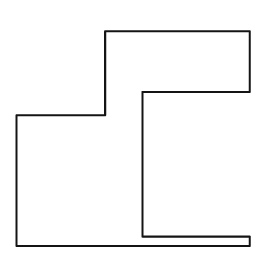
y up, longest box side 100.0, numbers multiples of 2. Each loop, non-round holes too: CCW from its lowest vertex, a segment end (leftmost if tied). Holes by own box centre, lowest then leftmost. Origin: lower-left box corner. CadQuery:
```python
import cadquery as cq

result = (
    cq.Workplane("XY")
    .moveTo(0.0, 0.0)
    .lineTo(100.0, 0.0)
    .lineTo(100.0, 4.0)
    .lineTo(54.0, 4.0)
    .lineTo(54.0, 66.0)
    .lineTo(100.0, 66.0)
    .lineTo(100.0, 92.0)
    .lineTo(38.0, 92.0)
    .lineTo(38.0, 56.0)
    .lineTo(0.0, 56.0)
    .close()
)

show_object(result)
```